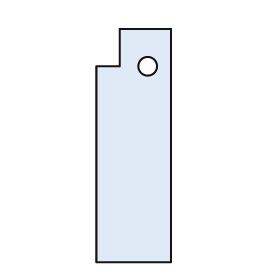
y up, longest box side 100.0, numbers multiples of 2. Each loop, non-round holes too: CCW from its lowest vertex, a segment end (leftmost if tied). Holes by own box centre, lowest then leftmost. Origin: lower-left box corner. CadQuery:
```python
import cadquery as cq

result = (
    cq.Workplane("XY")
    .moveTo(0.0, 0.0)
    .lineTo(32.0, 0.0)
    .lineTo(32.0, 100.0)
    .lineTo(10.0, 100.0)
    .lineTo(10.0, 84.0)
    .lineTo(0.0, 84.0)
    .close()
    .moveTo(22.0, 84.0)
    .circle(4.0)
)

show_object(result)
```